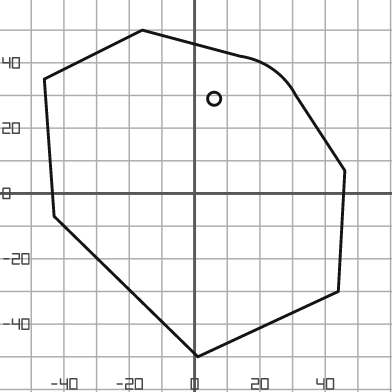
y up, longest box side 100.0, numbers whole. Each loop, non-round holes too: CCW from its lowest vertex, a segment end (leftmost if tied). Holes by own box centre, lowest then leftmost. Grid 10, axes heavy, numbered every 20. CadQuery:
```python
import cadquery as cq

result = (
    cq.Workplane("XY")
    .moveTo(1.0, -50.0)
    .lineTo(44.0, -30.0)
    .lineTo(46.0, 7.0)
    .lineTo(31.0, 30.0)
    .threePointArc((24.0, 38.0), (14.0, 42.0))
    .lineTo(-16.0, 50.0)
    .lineTo(-46.0, 35.0)
    .lineTo(-43.0, -7.0)
    .close()
    .moveTo(6.0, 29.0)
    .circle(2.0)
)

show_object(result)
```